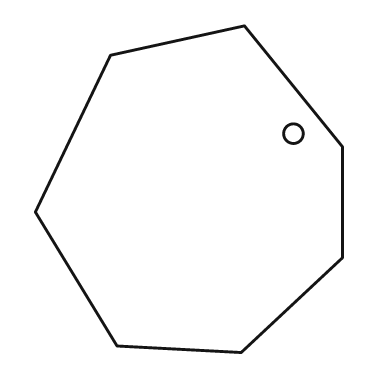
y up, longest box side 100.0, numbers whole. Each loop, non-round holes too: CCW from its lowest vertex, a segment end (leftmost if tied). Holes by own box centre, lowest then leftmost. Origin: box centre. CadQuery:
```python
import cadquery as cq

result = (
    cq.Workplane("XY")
    .moveTo(16.0, -50.0)
    .lineTo(47.0, -21.0)
    .lineTo(47.0, 13.0)
    .lineTo(17.0, 50.0)
    .lineTo(-24.0, 41.0)
    .lineTo(-47.0, -7.0)
    .lineTo(-22.0, -48.0)
    .close()
    .moveTo(32.0, 17.0)
    .circle(3.0)
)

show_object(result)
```